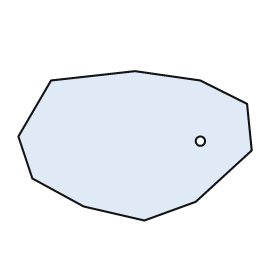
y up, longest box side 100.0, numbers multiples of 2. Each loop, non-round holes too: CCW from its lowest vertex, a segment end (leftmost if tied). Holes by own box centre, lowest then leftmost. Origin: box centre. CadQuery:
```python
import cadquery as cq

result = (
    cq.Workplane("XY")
    .moveTo(4.0, -32.0)
    .lineTo(26.0, -24.0)
    .lineTo(50.0, -2.0)
    .lineTo(48.0, 18.0)
    .lineTo(28.0, 28.0)
    .lineTo(0.0, 32.0)
    .lineTo(-36.0, 28.0)
    .lineTo(-50.0, 4.0)
    .lineTo(-44.0, -14.0)
    .lineTo(-22.0, -26.0)
    .close()
    .moveTo(28.0, 2.0)
    .circle(2.0)
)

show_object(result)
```